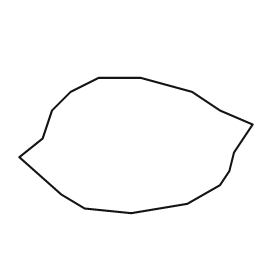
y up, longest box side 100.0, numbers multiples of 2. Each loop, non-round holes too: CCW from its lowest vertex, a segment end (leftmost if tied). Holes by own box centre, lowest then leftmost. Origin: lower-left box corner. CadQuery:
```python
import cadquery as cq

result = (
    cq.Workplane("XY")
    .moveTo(48.0, 0.0)
    .lineTo(72.0, 4.0)
    .lineTo(86.0, 12.0)
    .lineTo(90.0, 18.0)
    .lineTo(92.0, 26.0)
    .lineTo(100.0, 38.0)
    .lineTo(86.0, 44.0)
    .lineTo(74.0, 52.0)
    .lineTo(52.0, 58.0)
    .lineTo(34.0, 58.0)
    .lineTo(22.0, 52.0)
    .lineTo(14.0, 44.0)
    .lineTo(10.0, 32.0)
    .lineTo(0.0, 24.0)
    .lineTo(18.0, 8.0)
    .lineTo(28.0, 2.0)
    .close()
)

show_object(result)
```